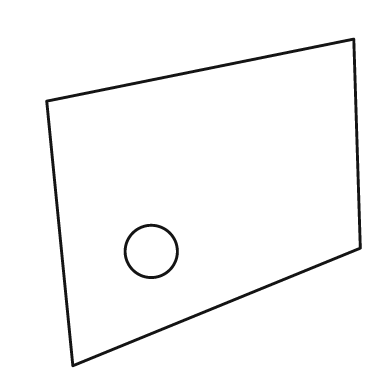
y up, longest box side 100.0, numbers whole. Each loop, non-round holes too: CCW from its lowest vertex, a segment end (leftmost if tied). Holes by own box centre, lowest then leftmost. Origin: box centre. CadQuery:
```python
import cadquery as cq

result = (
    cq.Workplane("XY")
    .moveTo(-40.0, -50.0)
    .lineTo(48.0, -14.0)
    .lineTo(46.0, 50.0)
    .lineTo(-48.0, 31.0)
    .close()
    .moveTo(-16.0, -15.0)
    .circle(8.0)
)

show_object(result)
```